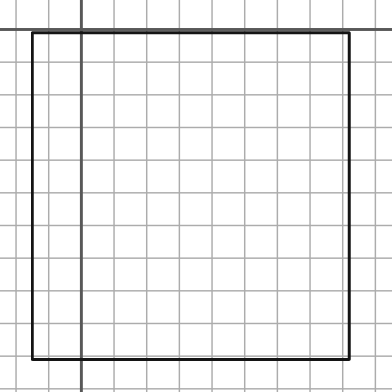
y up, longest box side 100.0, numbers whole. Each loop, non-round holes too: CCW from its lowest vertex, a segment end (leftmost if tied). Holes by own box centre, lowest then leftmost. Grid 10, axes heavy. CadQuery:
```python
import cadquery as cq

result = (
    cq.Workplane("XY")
    .moveTo(-15.0, -101.0)
    .lineTo(82.0, -101.0)
    .lineTo(82.0, -1.0)
    .lineTo(-15.0, -1.0)
    .close()
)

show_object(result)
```